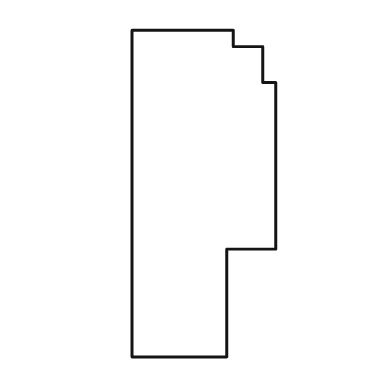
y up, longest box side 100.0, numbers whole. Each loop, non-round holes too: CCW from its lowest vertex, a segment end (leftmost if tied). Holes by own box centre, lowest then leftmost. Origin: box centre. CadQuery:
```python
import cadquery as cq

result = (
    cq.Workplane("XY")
    .moveTo(-22.0, -50.0)
    .lineTo(7.0, -50.0)
    .lineTo(7.0, -17.0)
    .lineTo(22.0, -17.0)
    .lineTo(22.0, 34.0)
    .lineTo(18.0, 34.0)
    .lineTo(18.0, 45.0)
    .lineTo(9.0, 45.0)
    .lineTo(9.0, 50.0)
    .lineTo(-22.0, 50.0)
    .close()
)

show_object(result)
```